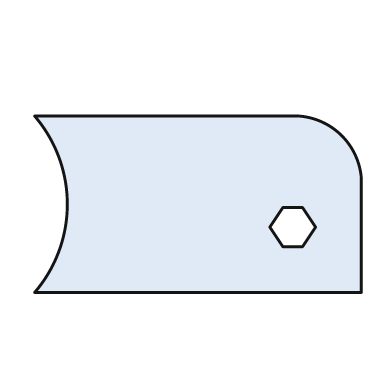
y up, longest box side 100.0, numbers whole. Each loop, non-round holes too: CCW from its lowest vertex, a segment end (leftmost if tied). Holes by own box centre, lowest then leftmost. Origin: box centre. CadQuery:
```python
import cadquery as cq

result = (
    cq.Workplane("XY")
    .moveTo(-50.0, -27.0)
    .lineTo(50.0, -27.0)
    .lineTo(50.0, 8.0)
    .threePointArc((44.0, 21.0), (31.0, 27.0))
    .lineTo(-50.0, 27.0)
    .threePointArc((-40.0, 0.0), (-50.0, -27.0))
    .close()
    .moveTo(26.0, -13.0)
    .lineTo(32.0, -13.0)
    .lineTo(36.0, -7.0)
    .lineTo(32.0, -1.0)
    .lineTo(26.0, -1.0)
    .lineTo(22.0, -7.0)
    .close()
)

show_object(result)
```